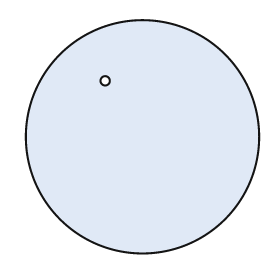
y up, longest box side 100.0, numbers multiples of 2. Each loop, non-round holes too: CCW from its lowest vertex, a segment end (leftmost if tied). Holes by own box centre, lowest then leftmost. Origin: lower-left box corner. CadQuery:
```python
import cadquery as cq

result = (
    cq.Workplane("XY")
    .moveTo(50.0, 50.0)
    .circle(50.0)
    .moveTo(34.0, 74.0)
    .circle(2.0)
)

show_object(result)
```